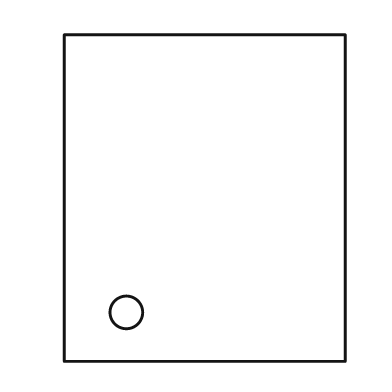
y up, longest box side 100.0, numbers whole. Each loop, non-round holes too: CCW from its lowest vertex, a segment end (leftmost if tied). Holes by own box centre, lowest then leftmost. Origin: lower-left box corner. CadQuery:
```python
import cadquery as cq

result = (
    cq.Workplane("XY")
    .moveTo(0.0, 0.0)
    .lineTo(86.0, 0.0)
    .lineTo(86.0, 100.0)
    .lineTo(0.0, 100.0)
    .close()
    .moveTo(19.0, 15.0)
    .circle(5.0)
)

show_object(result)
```